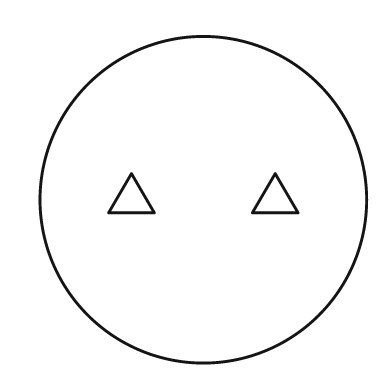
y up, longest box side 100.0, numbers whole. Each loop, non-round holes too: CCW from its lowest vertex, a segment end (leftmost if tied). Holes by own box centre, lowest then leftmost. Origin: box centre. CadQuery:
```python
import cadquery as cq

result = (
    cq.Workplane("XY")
    .moveTo(0.0, 0.0)
    .circle(50.0)
    .moveTo(-29.0, -4.0)
    .lineTo(-15.0, -4.0)
    .lineTo(-22.0, 8.0)
    .close()
    .moveTo(15.0, -4.0)
    .lineTo(29.0, -4.0)
    .lineTo(22.0, 8.0)
    .close()
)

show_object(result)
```